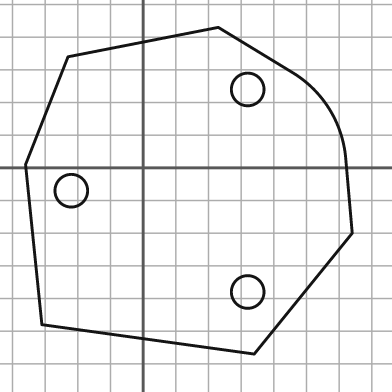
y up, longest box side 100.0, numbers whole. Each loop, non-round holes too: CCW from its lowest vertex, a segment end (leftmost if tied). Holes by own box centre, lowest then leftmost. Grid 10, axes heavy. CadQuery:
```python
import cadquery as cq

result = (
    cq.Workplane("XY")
    .moveTo(34.0, -57.0)
    .lineTo(64.0, -20.0)
    .lineTo(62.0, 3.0)
    .threePointArc((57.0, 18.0), (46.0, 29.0))
    .lineTo(23.0, 43.0)
    .lineTo(-23.0, 34.0)
    .lineTo(-36.0, 1.0)
    .lineTo(-31.0, -48.0)
    .close()
    .moveTo(32.0, -38.0)
    .circle(5.0)
    .moveTo(-22.0, -7.0)
    .circle(5.0)
    .moveTo(32.0, 24.0)
    .circle(5.0)
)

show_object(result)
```